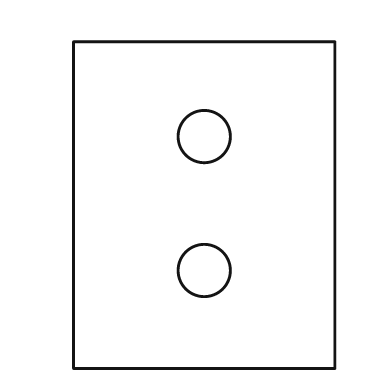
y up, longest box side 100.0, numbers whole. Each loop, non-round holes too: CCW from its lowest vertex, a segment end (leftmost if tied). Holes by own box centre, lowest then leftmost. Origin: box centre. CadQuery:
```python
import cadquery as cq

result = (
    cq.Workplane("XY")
    .moveTo(-40.0, -50.0)
    .lineTo(40.0, -50.0)
    .lineTo(40.0, 50.0)
    .lineTo(-40.0, 50.0)
    .close()
    .moveTo(0.0, -20.0)
    .circle(8.0)
    .moveTo(0.0, 21.0)
    .circle(8.0)
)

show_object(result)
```